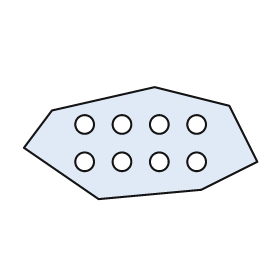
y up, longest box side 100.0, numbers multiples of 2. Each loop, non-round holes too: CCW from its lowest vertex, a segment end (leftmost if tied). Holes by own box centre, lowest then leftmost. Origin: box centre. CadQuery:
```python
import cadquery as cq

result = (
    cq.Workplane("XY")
    .moveTo(-18.0, -24.0)
    .lineTo(26.0, -20.0)
    .lineTo(50.0, -8.0)
    .lineTo(38.0, 16.0)
    .lineTo(6.0, 24.0)
    .lineTo(-38.0, 14.0)
    .lineTo(-50.0, -2.0)
    .close()
    .moveTo(-24.0, -8.0)
    .circle(4.0)
    .moveTo(-8.0, -8.0)
    .circle(4.0)
    .moveTo(8.0, -8.0)
    .circle(4.0)
    .moveTo(24.0, -8.0)
    .circle(4.0)
    .moveTo(-24.0, 8.0)
    .circle(4.0)
    .moveTo(-8.0, 8.0)
    .circle(4.0)
    .moveTo(8.0, 8.0)
    .circle(4.0)
    .moveTo(24.0, 8.0)
    .circle(4.0)
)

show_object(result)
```